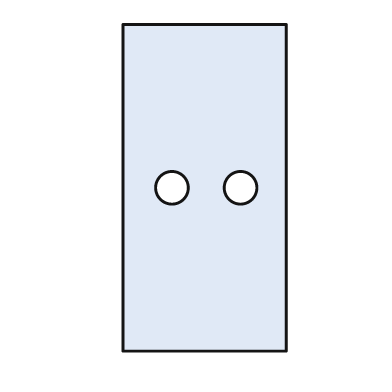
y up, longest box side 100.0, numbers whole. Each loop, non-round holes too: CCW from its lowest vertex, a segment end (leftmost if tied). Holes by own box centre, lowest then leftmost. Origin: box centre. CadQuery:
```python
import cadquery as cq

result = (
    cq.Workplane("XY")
    .moveTo(-25.0, -50.0)
    .lineTo(25.0, -50.0)
    .lineTo(25.0, 50.0)
    .lineTo(-25.0, 50.0)
    .close()
    .moveTo(-10.0, 0.0)
    .circle(5.0)
    .moveTo(11.0, 0.0)
    .circle(5.0)
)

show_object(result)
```